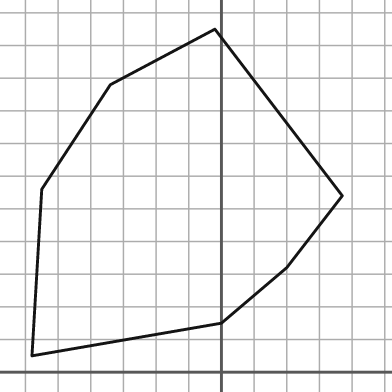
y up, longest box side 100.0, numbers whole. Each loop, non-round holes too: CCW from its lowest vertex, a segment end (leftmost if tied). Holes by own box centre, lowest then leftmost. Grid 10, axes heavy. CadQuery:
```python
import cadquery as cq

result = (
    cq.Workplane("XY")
    .moveTo(-58.0, 5.0)
    .lineTo(0.0, 15.0)
    .lineTo(20.0, 32.0)
    .lineTo(37.0, 54.0)
    .lineTo(-2.0, 105.0)
    .lineTo(-34.0, 88.0)
    .lineTo(-55.0, 56.0)
    .close()
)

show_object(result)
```